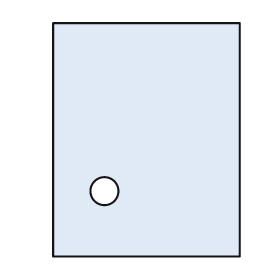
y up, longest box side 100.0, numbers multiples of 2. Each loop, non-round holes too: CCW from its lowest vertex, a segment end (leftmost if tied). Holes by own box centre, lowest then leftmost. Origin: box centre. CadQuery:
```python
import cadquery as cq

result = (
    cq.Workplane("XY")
    .moveTo(-40.0, -50.0)
    .lineTo(40.0, -50.0)
    .lineTo(40.0, 50.0)
    .lineTo(-40.0, 50.0)
    .close()
    .moveTo(-18.0, -22.0)
    .circle(6.0)
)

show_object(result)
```